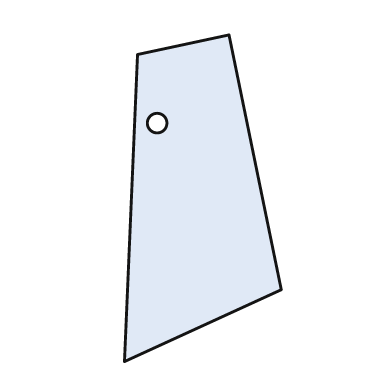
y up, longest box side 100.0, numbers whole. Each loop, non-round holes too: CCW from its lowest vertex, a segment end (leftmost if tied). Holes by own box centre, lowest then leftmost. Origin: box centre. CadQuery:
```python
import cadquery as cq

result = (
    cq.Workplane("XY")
    .moveTo(-24.0, -50.0)
    .lineTo(24.0, -28.0)
    .lineTo(8.0, 50.0)
    .lineTo(-20.0, 44.0)
    .close()
    .moveTo(-14.0, 23.0)
    .circle(3.0)
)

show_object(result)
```